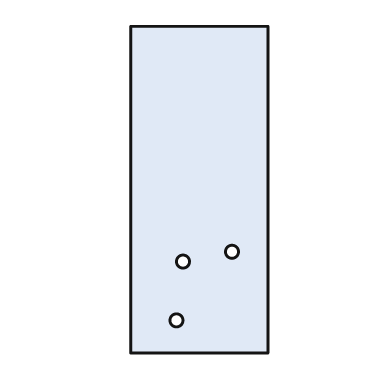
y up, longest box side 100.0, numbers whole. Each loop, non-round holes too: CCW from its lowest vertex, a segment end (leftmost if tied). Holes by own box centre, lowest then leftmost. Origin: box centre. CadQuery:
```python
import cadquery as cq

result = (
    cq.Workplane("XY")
    .moveTo(-21.0, -50.0)
    .lineTo(21.0, -50.0)
    .lineTo(21.0, 50.0)
    .lineTo(-21.0, 50.0)
    .close()
    .moveTo(-7.0, -40.0)
    .circle(2.0)
    .moveTo(-5.0, -22.0)
    .circle(2.0)
    .moveTo(10.0, -19.0)
    .circle(2.0)
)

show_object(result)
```